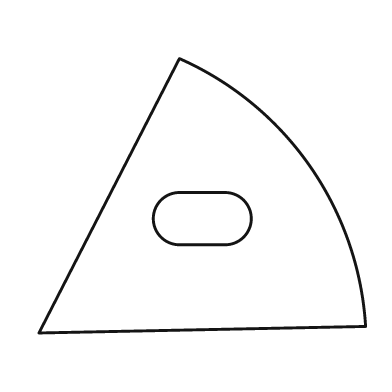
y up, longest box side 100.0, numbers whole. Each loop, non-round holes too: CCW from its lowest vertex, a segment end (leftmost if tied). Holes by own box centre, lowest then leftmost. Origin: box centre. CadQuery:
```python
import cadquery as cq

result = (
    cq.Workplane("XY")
    .moveTo(-50.0, -42.0)
    .lineTo(50.0, -40.0)
    .threePointArc((33.0, 9.0), (-7.0, 42.0))
    .close()
    .moveTo(-7.0, -15.0)
    .lineTo(7.0, -15.0)
    .threePointArc((15.0, -7.0), (7.0, 1.0))
    .lineTo(-7.0, 1.0)
    .threePointArc((-15.0, -7.0), (-7.0, -15.0))
    .close()
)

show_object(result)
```